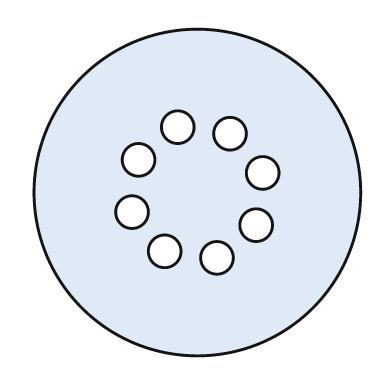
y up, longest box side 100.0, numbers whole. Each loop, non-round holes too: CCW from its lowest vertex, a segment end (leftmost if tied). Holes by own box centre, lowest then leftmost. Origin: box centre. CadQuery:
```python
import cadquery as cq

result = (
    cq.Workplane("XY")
    .moveTo(0.0, 0.0)
    .circle(50.0)
    .moveTo(6.0, -20.0)
    .circle(5.0)
    .moveTo(-10.0, -18.0)
    .circle(5.0)
    .moveTo(18.0, -10.0)
    .circle(5.0)
    .moveTo(-20.0, -6.0)
    .circle(5.0)
    .moveTo(20.0, 6.0)
    .circle(5.0)
    .moveTo(-18.0, 10.0)
    .circle(5.0)
    .moveTo(10.0, 18.0)
    .circle(5.0)
    .moveTo(-6.0, 20.0)
    .circle(5.0)
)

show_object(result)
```